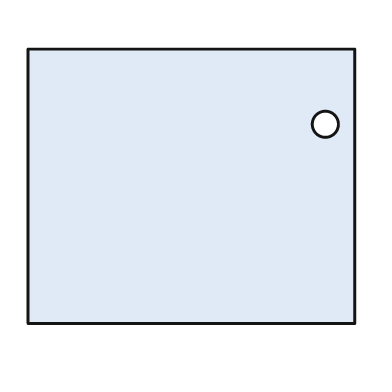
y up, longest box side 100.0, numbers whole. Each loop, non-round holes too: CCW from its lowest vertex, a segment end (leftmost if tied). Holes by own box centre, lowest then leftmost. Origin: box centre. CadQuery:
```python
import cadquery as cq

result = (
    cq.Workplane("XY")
    .moveTo(-50.0, -42.0)
    .lineTo(50.0, -42.0)
    .lineTo(50.0, 42.0)
    .lineTo(-50.0, 42.0)
    .close()
    .moveTo(41.0, 19.0)
    .circle(4.0)
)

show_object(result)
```